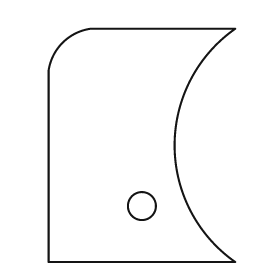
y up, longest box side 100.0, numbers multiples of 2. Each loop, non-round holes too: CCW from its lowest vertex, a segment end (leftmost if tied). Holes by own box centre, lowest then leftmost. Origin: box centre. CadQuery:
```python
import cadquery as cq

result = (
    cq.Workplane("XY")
    .moveTo(-40.0, -50.0)
    .lineTo(40.0, -50.0)
    .threePointArc((14.0, 0.0), (40.0, 50.0))
    .lineTo(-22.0, 50.0)
    .threePointArc((-34.0, 44.0), (-40.0, 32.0))
    .close()
    .moveTo(0.0, -26.0)
    .circle(6.0)
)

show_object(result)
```